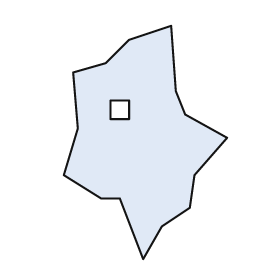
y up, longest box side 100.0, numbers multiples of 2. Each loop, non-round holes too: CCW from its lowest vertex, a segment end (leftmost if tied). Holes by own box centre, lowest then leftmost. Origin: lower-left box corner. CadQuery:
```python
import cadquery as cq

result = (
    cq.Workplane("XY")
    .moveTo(34.0, 0.0)
    .lineTo(42.0, 14.0)
    .lineTo(54.0, 22.0)
    .lineTo(56.0, 36.0)
    .lineTo(70.0, 52.0)
    .lineTo(52.0, 62.0)
    .lineTo(48.0, 72.0)
    .lineTo(46.0, 100.0)
    .lineTo(28.0, 94.0)
    .lineTo(18.0, 84.0)
    .lineTo(4.0, 80.0)
    .lineTo(6.0, 56.0)
    .lineTo(0.0, 36.0)
    .lineTo(16.0, 26.0)
    .lineTo(24.0, 26.0)
    .close()
    .moveTo(20.0, 60.0)
    .lineTo(28.0, 60.0)
    .lineTo(28.0, 68.0)
    .lineTo(20.0, 68.0)
    .close()
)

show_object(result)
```